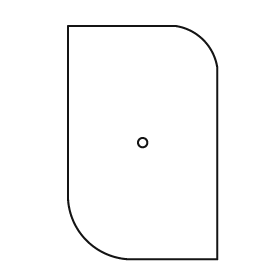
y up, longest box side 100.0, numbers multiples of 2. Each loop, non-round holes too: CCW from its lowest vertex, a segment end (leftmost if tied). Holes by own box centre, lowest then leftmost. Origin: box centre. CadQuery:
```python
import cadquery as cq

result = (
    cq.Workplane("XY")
    .moveTo(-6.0, -50.0)
    .lineTo(32.0, -50.0)
    .lineTo(32.0, 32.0)
    .threePointArc((26.0, 44.0), (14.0, 50.0))
    .lineTo(-32.0, 50.0)
    .lineTo(-32.0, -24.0)
    .threePointArc((-24.0, -42.0), (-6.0, -50.0))
    .close()
    .moveTo(0.0, 0.0)
    .circle(2.0)
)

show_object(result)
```